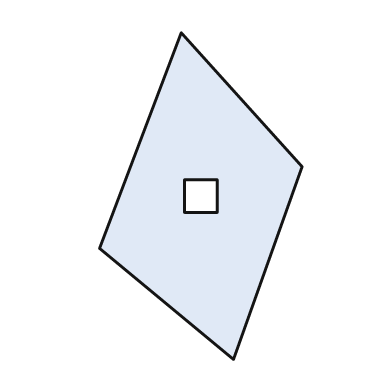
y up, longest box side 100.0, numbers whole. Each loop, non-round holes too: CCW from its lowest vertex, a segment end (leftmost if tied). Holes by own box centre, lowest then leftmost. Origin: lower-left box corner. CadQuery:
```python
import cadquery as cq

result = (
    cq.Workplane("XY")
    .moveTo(41.0, 0.0)
    .lineTo(62.0, 59.0)
    .lineTo(25.0, 100.0)
    .lineTo(0.0, 34.0)
    .close()
    .moveTo(26.0, 45.0)
    .lineTo(36.0, 45.0)
    .lineTo(36.0, 55.0)
    .lineTo(26.0, 55.0)
    .close()
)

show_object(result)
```